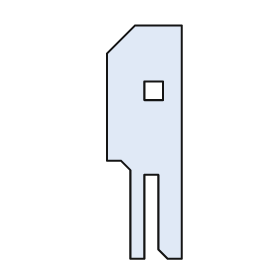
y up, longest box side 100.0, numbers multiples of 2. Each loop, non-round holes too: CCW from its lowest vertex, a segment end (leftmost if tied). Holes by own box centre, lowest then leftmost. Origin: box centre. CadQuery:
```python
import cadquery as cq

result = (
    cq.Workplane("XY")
    .moveTo(-6.0, -50.0)
    .lineTo(0.0, -50.0)
    .lineTo(0.0, -14.0)
    .lineTo(6.0, -14.0)
    .lineTo(6.0, -46.0)
    .lineTo(10.0, -50.0)
    .lineTo(16.0, -50.0)
    .lineTo(16.0, 50.0)
    .lineTo(-4.0, 50.0)
    .lineTo(-16.0, 38.0)
    .lineTo(-16.0, -8.0)
    .lineTo(-10.0, -8.0)
    .lineTo(-6.0, -12.0)
    .close()
    .moveTo(0.0, 18.0)
    .lineTo(8.0, 18.0)
    .lineTo(8.0, 26.0)
    .lineTo(0.0, 26.0)
    .close()
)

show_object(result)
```